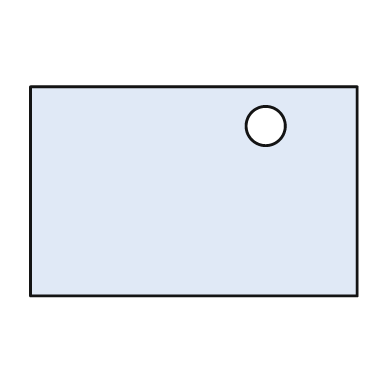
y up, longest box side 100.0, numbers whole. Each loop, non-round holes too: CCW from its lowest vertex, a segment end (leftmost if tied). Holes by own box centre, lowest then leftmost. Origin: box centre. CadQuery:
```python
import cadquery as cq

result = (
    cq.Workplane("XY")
    .moveTo(-50.0, -32.0)
    .lineTo(50.0, -32.0)
    .lineTo(50.0, 32.0)
    .lineTo(-50.0, 32.0)
    .close()
    .moveTo(22.0, 20.0)
    .circle(6.0)
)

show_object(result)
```